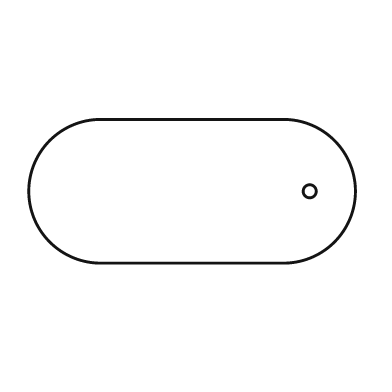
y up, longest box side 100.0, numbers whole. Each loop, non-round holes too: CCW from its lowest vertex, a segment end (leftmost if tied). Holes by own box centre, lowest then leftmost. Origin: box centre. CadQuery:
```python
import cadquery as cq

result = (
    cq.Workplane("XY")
    .moveTo(-28.0, -22.0)
    .lineTo(28.0, -22.0)
    .threePointArc((50.0, 0.0), (28.0, 22.0))
    .lineTo(-28.0, 22.0)
    .threePointArc((-50.0, 0.0), (-28.0, -22.0))
    .close()
    .moveTo(36.0, 0.0)
    .circle(2.0)
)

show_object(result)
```